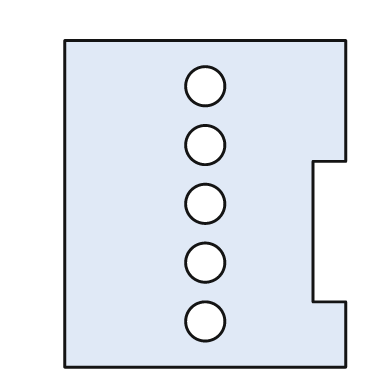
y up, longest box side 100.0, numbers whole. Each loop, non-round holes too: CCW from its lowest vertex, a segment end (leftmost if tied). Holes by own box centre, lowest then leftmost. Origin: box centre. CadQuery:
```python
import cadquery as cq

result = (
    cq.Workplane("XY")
    .moveTo(-43.0, -50.0)
    .lineTo(43.0, -50.0)
    .lineTo(43.0, -30.0)
    .lineTo(33.0, -30.0)
    .lineTo(33.0, 13.0)
    .lineTo(43.0, 13.0)
    .lineTo(43.0, 50.0)
    .lineTo(-43.0, 50.0)
    .close()
    .moveTo(0.0, -36.0)
    .circle(6.0)
    .moveTo(0.0, -18.0)
    .circle(6.0)
    .moveTo(0.0, 0.0)
    .circle(6.0)
    .moveTo(0.0, 18.0)
    .circle(6.0)
    .moveTo(0.0, 36.0)
    .circle(6.0)
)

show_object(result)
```